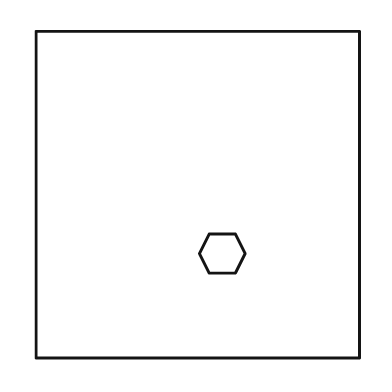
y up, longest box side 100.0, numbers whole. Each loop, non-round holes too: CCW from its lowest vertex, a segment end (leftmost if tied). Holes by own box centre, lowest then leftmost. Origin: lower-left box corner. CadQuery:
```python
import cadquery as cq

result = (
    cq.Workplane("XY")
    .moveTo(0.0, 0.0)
    .lineTo(99.0, 0.0)
    .lineTo(99.0, 100.0)
    .lineTo(0.0, 100.0)
    .close()
    .moveTo(53.0, 26.0)
    .lineTo(61.0, 26.0)
    .lineTo(64.0, 32.0)
    .lineTo(61.0, 38.0)
    .lineTo(53.0, 38.0)
    .lineTo(50.0, 32.0)
    .close()
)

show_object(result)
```